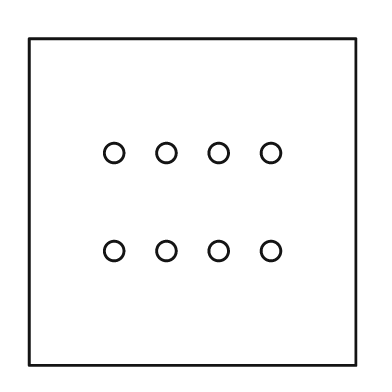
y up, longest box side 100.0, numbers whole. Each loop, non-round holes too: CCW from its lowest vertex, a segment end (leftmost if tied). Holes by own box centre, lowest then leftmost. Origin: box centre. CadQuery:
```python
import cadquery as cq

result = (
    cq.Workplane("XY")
    .moveTo(-50.0, -50.0)
    .lineTo(50.0, -50.0)
    .lineTo(50.0, 50.0)
    .lineTo(-50.0, 50.0)
    .close()
    .moveTo(-24.0, -15.0)
    .circle(3.0)
    .moveTo(-8.0, -15.0)
    .circle(3.0)
    .moveTo(8.0, -15.0)
    .circle(3.0)
    .moveTo(24.0, -15.0)
    .circle(3.0)
    .moveTo(-24.0, 15.0)
    .circle(3.0)
    .moveTo(-8.0, 15.0)
    .circle(3.0)
    .moveTo(8.0, 15.0)
    .circle(3.0)
    .moveTo(24.0, 15.0)
    .circle(3.0)
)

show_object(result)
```